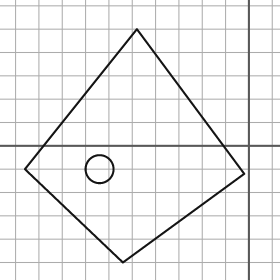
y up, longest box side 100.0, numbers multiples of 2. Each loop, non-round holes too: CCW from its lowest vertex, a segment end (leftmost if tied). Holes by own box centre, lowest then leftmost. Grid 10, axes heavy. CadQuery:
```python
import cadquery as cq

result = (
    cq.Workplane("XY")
    .moveTo(-54.0, -50.0)
    .lineTo(-2.0, -12.0)
    .lineTo(-48.0, 50.0)
    .lineTo(-96.0, -10.0)
    .close()
    .moveTo(-64.0, -10.0)
    .circle(6.0)
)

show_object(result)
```